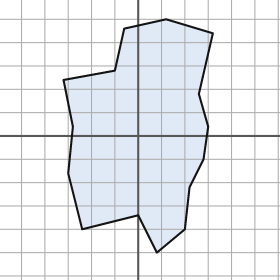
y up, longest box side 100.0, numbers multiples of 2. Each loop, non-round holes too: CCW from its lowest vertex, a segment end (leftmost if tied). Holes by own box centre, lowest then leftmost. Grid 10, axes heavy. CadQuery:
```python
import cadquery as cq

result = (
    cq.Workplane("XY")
    .moveTo(8.0, -50.0)
    .lineTo(20.0, -40.0)
    .lineTo(22.0, -22.0)
    .lineTo(28.0, -10.0)
    .lineTo(30.0, 4.0)
    .lineTo(26.0, 18.0)
    .lineTo(32.0, 44.0)
    .lineTo(12.0, 50.0)
    .lineTo(-6.0, 46.0)
    .lineTo(-10.0, 28.0)
    .lineTo(-32.0, 24.0)
    .lineTo(-28.0, 4.0)
    .lineTo(-30.0, -16.0)
    .lineTo(-24.0, -40.0)
    .lineTo(0.0, -34.0)
    .close()
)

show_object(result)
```